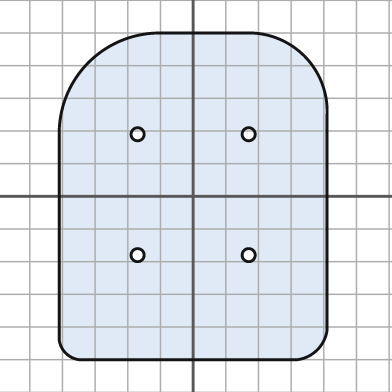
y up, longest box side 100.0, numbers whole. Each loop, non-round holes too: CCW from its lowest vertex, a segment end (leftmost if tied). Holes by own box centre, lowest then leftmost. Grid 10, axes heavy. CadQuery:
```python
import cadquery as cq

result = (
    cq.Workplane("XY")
    .moveTo(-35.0, -50.0)
    .lineTo(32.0, -50.0)
    .threePointArc((38.0, -47.0), (41.0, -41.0))
    .lineTo(41.0, 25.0)
    .threePointArc((34.0, 43.0), (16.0, 50.0))
    .lineTo(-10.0, 50.0)
    .threePointArc((-32.0, 41.0), (-41.0, 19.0))
    .lineTo(-41.0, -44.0)
    .threePointArc((-39.0, -48.0), (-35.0, -50.0))
    .close()
    .moveTo(-17.0, -18.0)
    .circle(2.0)
    .moveTo(17.0, -18.0)
    .circle(2.0)
    .moveTo(-17.0, 19.0)
    .circle(2.0)
    .moveTo(17.0, 19.0)
    .circle(2.0)
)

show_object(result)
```